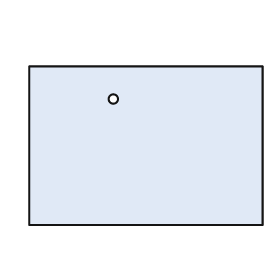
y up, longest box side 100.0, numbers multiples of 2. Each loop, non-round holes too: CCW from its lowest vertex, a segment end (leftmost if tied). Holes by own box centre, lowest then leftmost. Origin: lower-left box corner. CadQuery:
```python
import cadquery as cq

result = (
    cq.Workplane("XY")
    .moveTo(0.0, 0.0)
    .lineTo(100.0, 0.0)
    .lineTo(100.0, 68.0)
    .lineTo(0.0, 68.0)
    .close()
    .moveTo(36.0, 54.0)
    .circle(2.0)
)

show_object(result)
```